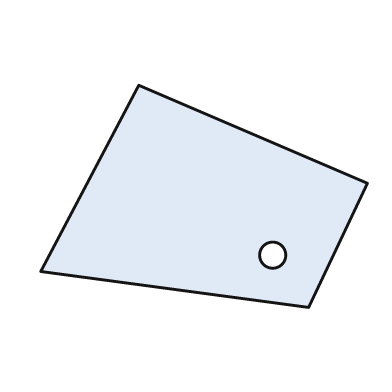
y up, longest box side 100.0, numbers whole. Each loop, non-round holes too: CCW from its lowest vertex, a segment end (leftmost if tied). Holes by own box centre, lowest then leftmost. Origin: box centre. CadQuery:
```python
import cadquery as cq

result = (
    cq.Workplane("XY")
    .moveTo(32.0, -34.0)
    .lineTo(50.0, 4.0)
    .lineTo(-20.0, 34.0)
    .lineTo(-50.0, -23.0)
    .close()
    .moveTo(21.0, -18.0)
    .circle(4.0)
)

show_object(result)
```